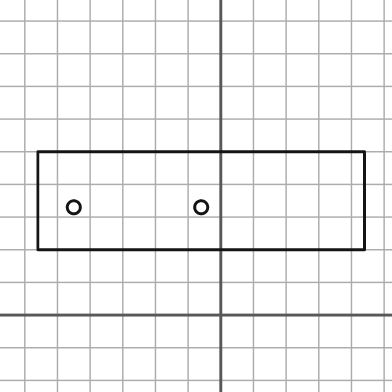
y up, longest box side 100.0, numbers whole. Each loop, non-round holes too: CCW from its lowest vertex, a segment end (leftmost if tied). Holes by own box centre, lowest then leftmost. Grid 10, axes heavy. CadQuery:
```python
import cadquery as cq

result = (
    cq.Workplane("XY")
    .moveTo(-56.0, 20.0)
    .lineTo(44.0, 20.0)
    .lineTo(44.0, 50.0)
    .lineTo(-56.0, 50.0)
    .close()
    .moveTo(-45.0, 33.0)
    .circle(2.0)
    .moveTo(-6.0, 33.0)
    .circle(2.0)
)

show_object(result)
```